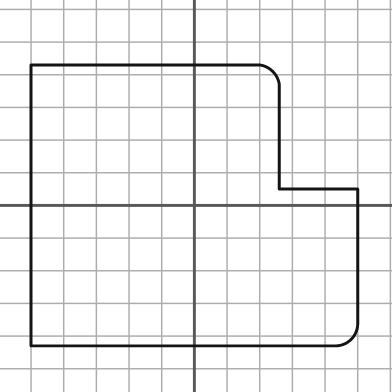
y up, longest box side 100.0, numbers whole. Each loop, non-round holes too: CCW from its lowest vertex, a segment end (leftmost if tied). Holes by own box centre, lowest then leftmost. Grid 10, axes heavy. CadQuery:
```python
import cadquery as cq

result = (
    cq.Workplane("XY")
    .moveTo(-50.0, -43.0)
    .lineTo(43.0, -43.0)
    .threePointArc((48.0, -41.0), (50.0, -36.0))
    .lineTo(50.0, 5.0)
    .lineTo(26.0, 5.0)
    .lineTo(26.0, 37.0)
    .threePointArc((24.0, 41.0), (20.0, 43.0))
    .lineTo(-50.0, 43.0)
    .close()
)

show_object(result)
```